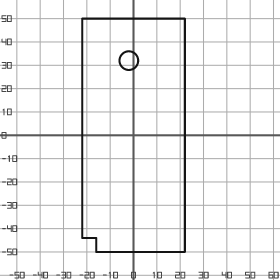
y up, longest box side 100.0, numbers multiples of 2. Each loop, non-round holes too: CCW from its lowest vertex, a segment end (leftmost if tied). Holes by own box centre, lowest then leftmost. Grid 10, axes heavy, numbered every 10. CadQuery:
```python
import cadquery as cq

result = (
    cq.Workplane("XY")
    .moveTo(-16.0, -50.0)
    .lineTo(22.0, -50.0)
    .lineTo(22.0, 50.0)
    .lineTo(-22.0, 50.0)
    .lineTo(-22.0, -44.0)
    .lineTo(-16.0, -44.0)
    .close()
    .moveTo(-2.0, 32.0)
    .circle(4.0)
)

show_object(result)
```